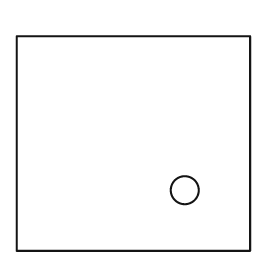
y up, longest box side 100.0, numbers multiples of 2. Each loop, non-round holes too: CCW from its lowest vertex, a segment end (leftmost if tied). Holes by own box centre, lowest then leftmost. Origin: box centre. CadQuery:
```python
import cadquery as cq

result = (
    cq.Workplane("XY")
    .moveTo(-50.0, -46.0)
    .lineTo(50.0, -46.0)
    .lineTo(50.0, 46.0)
    .lineTo(-50.0, 46.0)
    .close()
    .moveTo(22.0, -20.0)
    .circle(6.0)
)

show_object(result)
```